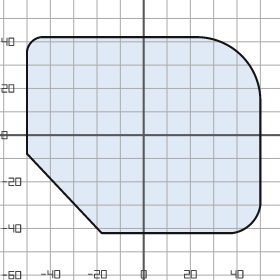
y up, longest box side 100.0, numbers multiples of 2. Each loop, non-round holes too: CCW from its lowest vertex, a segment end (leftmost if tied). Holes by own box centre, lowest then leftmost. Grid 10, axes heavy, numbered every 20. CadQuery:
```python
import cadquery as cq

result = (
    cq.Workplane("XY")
    .moveTo(-18.0, -42.0)
    .lineTo(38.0, -42.0)
    .threePointArc((46.0, -38.0), (50.0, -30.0))
    .lineTo(50.0, 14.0)
    .threePointArc((42.0, 34.0), (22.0, 42.0))
    .lineTo(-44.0, 42.0)
    .threePointArc((-48.0, 40.0), (-50.0, 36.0))
    .lineTo(-50.0, -8.0)
    .close()
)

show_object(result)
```